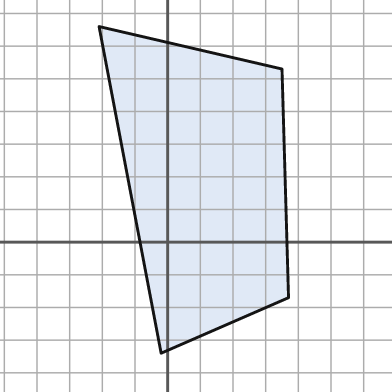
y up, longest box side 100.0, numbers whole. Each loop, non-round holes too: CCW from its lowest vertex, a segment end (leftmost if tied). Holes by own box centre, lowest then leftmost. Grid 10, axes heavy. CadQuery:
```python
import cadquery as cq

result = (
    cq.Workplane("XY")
    .moveTo(-2.0, -34.0)
    .lineTo(37.0, -17.0)
    .lineTo(35.0, 53.0)
    .lineTo(-21.0, 66.0)
    .close()
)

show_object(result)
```